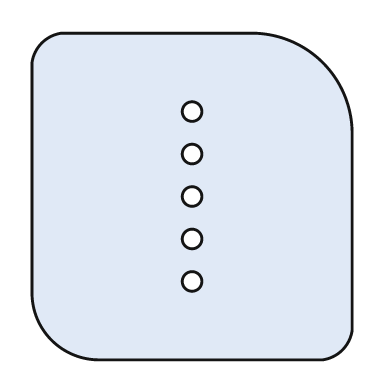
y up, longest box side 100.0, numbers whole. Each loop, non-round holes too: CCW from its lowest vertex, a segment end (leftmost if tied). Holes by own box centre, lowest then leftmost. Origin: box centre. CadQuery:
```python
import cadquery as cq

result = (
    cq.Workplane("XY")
    .moveTo(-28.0, -50.0)
    .lineTo(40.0, -50.0)
    .threePointArc((46.0, -47.0), (49.0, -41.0))
    .lineTo(49.0, 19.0)
    .threePointArc((40.0, 41.0), (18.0, 50.0))
    .lineTo(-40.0, 50.0)
    .threePointArc((-46.0, 47.0), (-49.0, 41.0))
    .lineTo(-49.0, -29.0)
    .threePointArc((-43.0, -44.0), (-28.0, -50.0))
    .close()
    .moveTo(0.0, -26.0)
    .circle(3.0)
    .moveTo(0.0, -13.0)
    .circle(3.0)
    .moveTo(0.0, 0.0)
    .circle(3.0)
    .moveTo(0.0, 13.0)
    .circle(3.0)
    .moveTo(0.0, 26.0)
    .circle(3.0)
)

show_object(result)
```